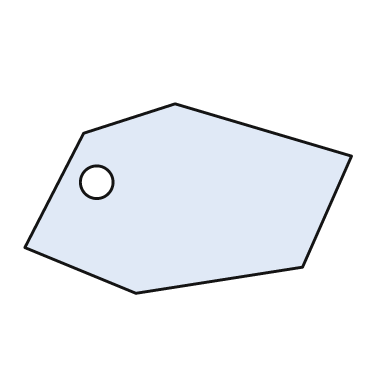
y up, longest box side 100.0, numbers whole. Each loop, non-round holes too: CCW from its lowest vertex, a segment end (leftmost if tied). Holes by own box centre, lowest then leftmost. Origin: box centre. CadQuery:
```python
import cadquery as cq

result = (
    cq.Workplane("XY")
    .moveTo(-16.0, -29.0)
    .lineTo(35.0, -21.0)
    .lineTo(50.0, 13.0)
    .lineTo(-4.0, 29.0)
    .lineTo(-32.0, 20.0)
    .lineTo(-50.0, -15.0)
    .close()
    .moveTo(-28.0, 5.0)
    .circle(5.0)
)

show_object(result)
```